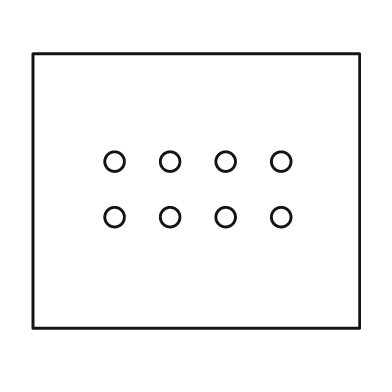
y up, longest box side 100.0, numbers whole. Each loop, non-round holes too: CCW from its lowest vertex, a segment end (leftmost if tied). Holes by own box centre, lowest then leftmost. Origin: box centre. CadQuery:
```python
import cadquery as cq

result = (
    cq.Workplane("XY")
    .moveTo(-50.0, -42.0)
    .lineTo(50.0, -42.0)
    .lineTo(50.0, 42.0)
    .lineTo(-50.0, 42.0)
    .close()
    .moveTo(-25.0, -8.0)
    .circle(3.0)
    .moveTo(-8.0, -8.0)
    .circle(3.0)
    .moveTo(9.0, -8.0)
    .circle(3.0)
    .moveTo(26.0, -8.0)
    .circle(3.0)
    .moveTo(-25.0, 9.0)
    .circle(3.0)
    .moveTo(-8.0, 9.0)
    .circle(3.0)
    .moveTo(9.0, 9.0)
    .circle(3.0)
    .moveTo(26.0, 9.0)
    .circle(3.0)
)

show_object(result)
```